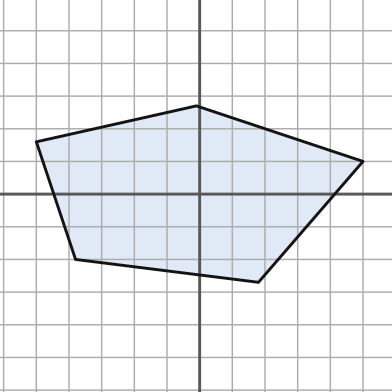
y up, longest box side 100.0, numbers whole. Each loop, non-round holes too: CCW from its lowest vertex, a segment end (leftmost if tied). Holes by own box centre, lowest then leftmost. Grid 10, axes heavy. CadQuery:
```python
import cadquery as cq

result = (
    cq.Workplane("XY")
    .moveTo(18.0, -27.0)
    .lineTo(50.0, 10.0)
    .lineTo(-1.0, 27.0)
    .lineTo(-50.0, 16.0)
    .lineTo(-38.0, -20.0)
    .close()
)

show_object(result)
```